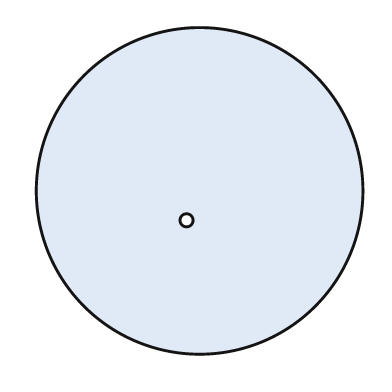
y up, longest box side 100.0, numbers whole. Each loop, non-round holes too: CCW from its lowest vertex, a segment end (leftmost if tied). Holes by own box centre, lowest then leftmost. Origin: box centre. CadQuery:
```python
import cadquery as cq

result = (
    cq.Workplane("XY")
    .moveTo(0.0, 0.0)
    .circle(50.0)
    .moveTo(-4.0, -9.0)
    .circle(2.0)
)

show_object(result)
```